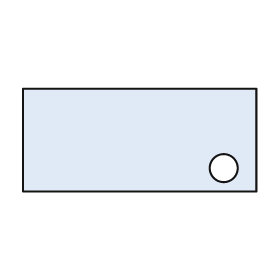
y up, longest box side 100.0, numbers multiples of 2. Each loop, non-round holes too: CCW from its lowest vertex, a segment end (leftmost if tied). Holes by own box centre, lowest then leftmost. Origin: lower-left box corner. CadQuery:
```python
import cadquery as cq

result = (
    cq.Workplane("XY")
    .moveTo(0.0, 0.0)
    .lineTo(100.0, 0.0)
    .lineTo(100.0, 44.0)
    .lineTo(0.0, 44.0)
    .close()
    .moveTo(86.0, 10.0)
    .circle(6.0)
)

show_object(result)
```